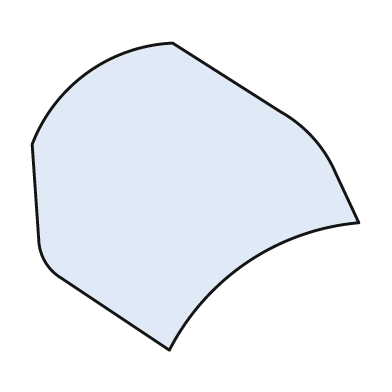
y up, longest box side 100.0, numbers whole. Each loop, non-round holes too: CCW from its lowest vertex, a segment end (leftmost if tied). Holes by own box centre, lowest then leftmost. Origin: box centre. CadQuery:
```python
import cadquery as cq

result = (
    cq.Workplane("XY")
    .moveTo(-8.0, -47.0)
    .threePointArc((16.0, -20.0), (50.0, -8.0))
    .lineTo(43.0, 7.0)
    .threePointArc((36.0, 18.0), (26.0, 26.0))
    .lineTo(-7.0, 47.0)
    .threePointArc((-33.0, 38.0), (-50.0, 16.0))
    .lineTo(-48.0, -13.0)
    .threePointArc((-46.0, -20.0), (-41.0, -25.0))
    .close()
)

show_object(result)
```